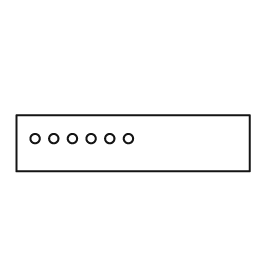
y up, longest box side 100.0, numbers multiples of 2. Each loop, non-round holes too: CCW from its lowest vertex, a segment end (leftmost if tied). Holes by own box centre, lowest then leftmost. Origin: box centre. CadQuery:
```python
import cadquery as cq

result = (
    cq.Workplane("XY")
    .moveTo(-50.0, -12.0)
    .lineTo(50.0, -12.0)
    .lineTo(50.0, 12.0)
    .lineTo(-50.0, 12.0)
    .close()
    .moveTo(-42.0, 2.0)
    .circle(2.0)
    .moveTo(-34.0, 2.0)
    .circle(2.0)
    .moveTo(-26.0, 2.0)
    .circle(2.0)
    .moveTo(-18.0, 2.0)
    .circle(2.0)
    .moveTo(-10.0, 2.0)
    .circle(2.0)
    .moveTo(-2.0, 2.0)
    .circle(2.0)
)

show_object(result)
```